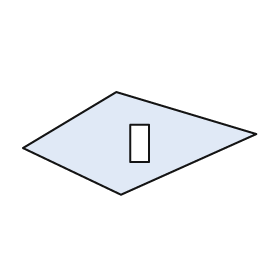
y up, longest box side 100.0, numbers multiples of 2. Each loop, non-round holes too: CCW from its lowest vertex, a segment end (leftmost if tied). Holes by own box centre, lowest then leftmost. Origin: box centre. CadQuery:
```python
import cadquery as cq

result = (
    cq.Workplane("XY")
    .moveTo(-8.0, -22.0)
    .lineTo(50.0, 4.0)
    .lineTo(-10.0, 22.0)
    .lineTo(-50.0, -2.0)
    .close()
    .moveTo(-4.0, -8.0)
    .lineTo(4.0, -8.0)
    .lineTo(4.0, 8.0)
    .lineTo(-4.0, 8.0)
    .close()
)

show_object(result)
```